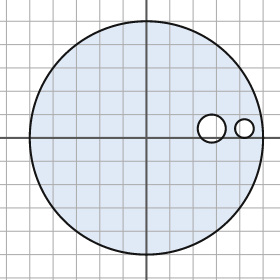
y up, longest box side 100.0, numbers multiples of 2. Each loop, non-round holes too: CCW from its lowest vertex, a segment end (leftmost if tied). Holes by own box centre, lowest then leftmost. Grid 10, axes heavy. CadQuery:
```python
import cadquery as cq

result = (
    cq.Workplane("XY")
    .moveTo(0.0, 0.0)
    .circle(50.0)
    .moveTo(28.0, 4.0)
    .circle(6.0)
    .moveTo(42.0, 4.0)
    .circle(4.0)
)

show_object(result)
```